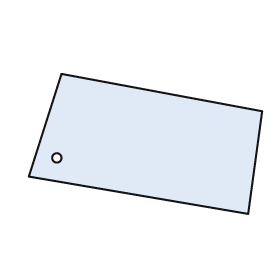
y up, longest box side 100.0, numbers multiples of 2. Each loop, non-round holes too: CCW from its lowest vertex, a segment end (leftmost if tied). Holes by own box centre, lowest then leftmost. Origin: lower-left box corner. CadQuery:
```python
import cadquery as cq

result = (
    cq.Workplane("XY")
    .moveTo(94.0, 0.0)
    .lineTo(100.0, 44.0)
    .lineTo(14.0, 60.0)
    .lineTo(0.0, 16.0)
    .close()
    .moveTo(12.0, 24.0)
    .circle(2.0)
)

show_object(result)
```